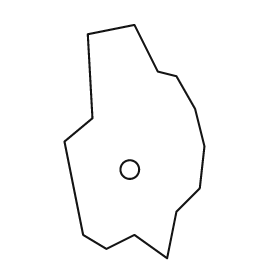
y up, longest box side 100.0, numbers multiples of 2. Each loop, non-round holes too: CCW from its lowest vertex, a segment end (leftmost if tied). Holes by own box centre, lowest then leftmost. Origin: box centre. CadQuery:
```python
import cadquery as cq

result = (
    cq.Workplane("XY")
    .moveTo(14.0, -50.0)
    .lineTo(18.0, -30.0)
    .lineTo(28.0, -20.0)
    .lineTo(30.0, -2.0)
    .lineTo(26.0, 14.0)
    .lineTo(18.0, 28.0)
    .lineTo(10.0, 30.0)
    .lineTo(0.0, 50.0)
    .lineTo(-20.0, 46.0)
    .lineTo(-18.0, 10.0)
    .lineTo(-30.0, 0.0)
    .lineTo(-22.0, -40.0)
    .lineTo(-12.0, -46.0)
    .lineTo(0.0, -40.0)
    .close()
    .moveTo(-2.0, -12.0)
    .circle(4.0)
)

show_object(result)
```